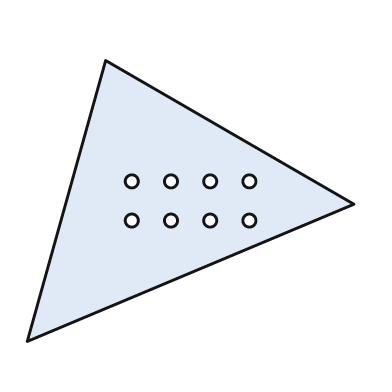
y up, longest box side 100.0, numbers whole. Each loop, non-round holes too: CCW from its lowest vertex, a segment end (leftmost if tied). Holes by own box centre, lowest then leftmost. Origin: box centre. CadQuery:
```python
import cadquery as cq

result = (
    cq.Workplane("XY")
    .moveTo(-50.0, -43.0)
    .lineTo(50.0, -1.0)
    .lineTo(-26.0, 43.0)
    .close()
    .moveTo(-18.0, -6.0)
    .circle(2.0)
    .moveTo(-6.0, -6.0)
    .circle(2.0)
    .moveTo(6.0, -6.0)
    .circle(2.0)
    .moveTo(18.0, -6.0)
    .circle(2.0)
    .moveTo(-18.0, 6.0)
    .circle(2.0)
    .moveTo(-6.0, 6.0)
    .circle(2.0)
    .moveTo(6.0, 6.0)
    .circle(2.0)
    .moveTo(18.0, 6.0)
    .circle(2.0)
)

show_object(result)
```